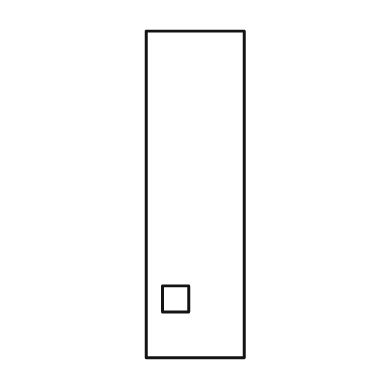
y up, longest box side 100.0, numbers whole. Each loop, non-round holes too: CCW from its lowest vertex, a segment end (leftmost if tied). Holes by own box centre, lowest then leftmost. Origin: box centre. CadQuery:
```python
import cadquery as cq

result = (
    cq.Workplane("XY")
    .moveTo(-15.0, -50.0)
    .lineTo(15.0, -50.0)
    .lineTo(15.0, 50.0)
    .lineTo(-15.0, 50.0)
    .close()
    .moveTo(-10.0, -36.0)
    .lineTo(-2.0, -36.0)
    .lineTo(-2.0, -28.0)
    .lineTo(-10.0, -28.0)
    .close()
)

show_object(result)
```